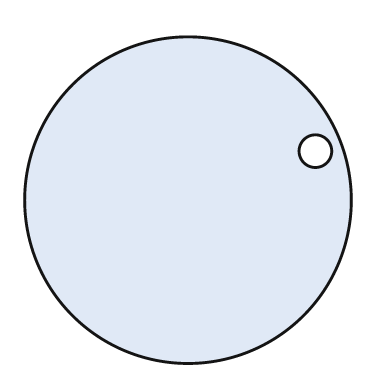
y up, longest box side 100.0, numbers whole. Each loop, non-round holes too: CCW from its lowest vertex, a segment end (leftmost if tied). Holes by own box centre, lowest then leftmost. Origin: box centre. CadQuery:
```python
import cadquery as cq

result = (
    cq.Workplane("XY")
    .moveTo(0.0, 0.0)
    .circle(50.0)
    .moveTo(39.0, 15.0)
    .circle(5.0)
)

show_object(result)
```